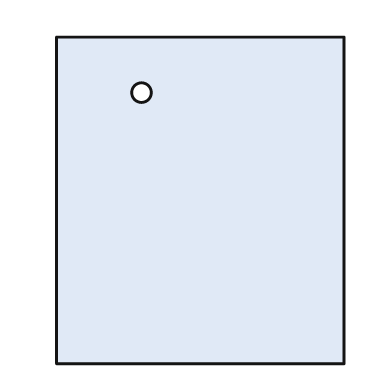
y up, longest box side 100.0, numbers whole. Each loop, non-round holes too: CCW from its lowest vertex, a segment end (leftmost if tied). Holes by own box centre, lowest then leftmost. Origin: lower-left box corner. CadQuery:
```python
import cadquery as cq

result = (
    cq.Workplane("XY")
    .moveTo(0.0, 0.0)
    .lineTo(88.0, 0.0)
    .lineTo(88.0, 100.0)
    .lineTo(0.0, 100.0)
    .close()
    .moveTo(26.0, 83.0)
    .circle(3.0)
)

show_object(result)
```